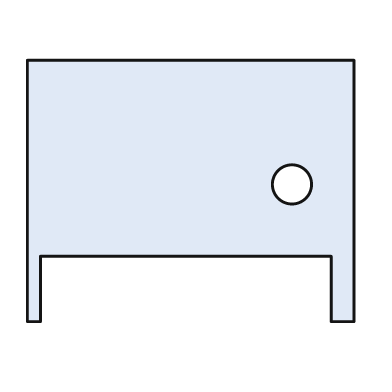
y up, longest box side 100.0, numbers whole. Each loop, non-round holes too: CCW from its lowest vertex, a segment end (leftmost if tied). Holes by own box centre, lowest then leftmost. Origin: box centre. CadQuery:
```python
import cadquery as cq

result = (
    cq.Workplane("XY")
    .moveTo(-50.0, -40.0)
    .lineTo(-46.0, -40.0)
    .lineTo(-46.0, -20.0)
    .lineTo(43.0, -20.0)
    .lineTo(43.0, -40.0)
    .lineTo(50.0, -40.0)
    .lineTo(50.0, 40.0)
    .lineTo(-50.0, 40.0)
    .close()
    .moveTo(31.0, 2.0)
    .circle(6.0)
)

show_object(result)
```